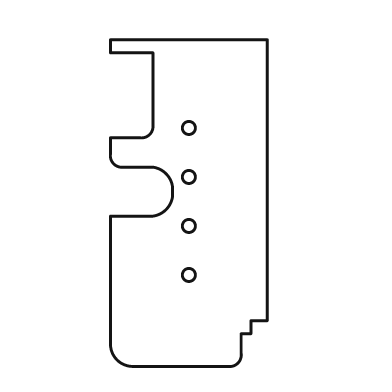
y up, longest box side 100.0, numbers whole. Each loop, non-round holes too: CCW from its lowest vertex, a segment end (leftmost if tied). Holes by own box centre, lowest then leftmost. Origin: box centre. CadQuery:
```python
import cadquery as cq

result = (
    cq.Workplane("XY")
    .moveTo(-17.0, -50.0)
    .lineTo(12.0, -50.0)
    .threePointArc((15.0, -49.0), (16.0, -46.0))
    .lineTo(16.0, -40.0)
    .lineTo(19.0, -40.0)
    .lineTo(19.0, -36.0)
    .lineTo(24.0, -36.0)
    .lineTo(24.0, 50.0)
    .lineTo(-24.0, 50.0)
    .lineTo(-24.0, 46.0)
    .lineTo(-11.0, 46.0)
    .lineTo(-11.0, 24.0)
    .threePointArc((-12.0, 21.0), (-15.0, 20.0))
    .lineTo(-24.0, 20.0)
    .lineTo(-24.0, 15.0)
    .threePointArc((-23.0, 12.0), (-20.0, 11.0))
    .lineTo(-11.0, 11.0)
    .threePointArc((-7.0, 9.0), (-5.0, 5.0))
    .lineTo(-5.0, 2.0)
    .threePointArc((-7.0, -2.0), (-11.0, -4.0))
    .lineTo(-24.0, -4.0)
    .lineTo(-24.0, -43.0)
    .threePointArc((-22.0, -48.0), (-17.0, -50.0))
    .close()
    .moveTo(0.0, -22.0)
    .circle(2.0)
    .moveTo(0.0, -7.0)
    .circle(2.0)
    .moveTo(0.0, 8.0)
    .circle(2.0)
    .moveTo(0.0, 23.0)
    .circle(2.0)
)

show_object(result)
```